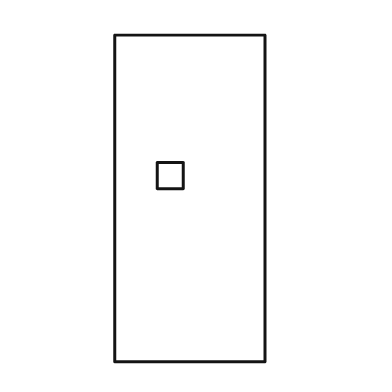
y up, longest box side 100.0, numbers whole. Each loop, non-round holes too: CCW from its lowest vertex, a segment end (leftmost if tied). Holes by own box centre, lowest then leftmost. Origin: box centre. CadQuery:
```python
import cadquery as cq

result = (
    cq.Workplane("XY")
    .moveTo(-23.0, -50.0)
    .lineTo(23.0, -50.0)
    .lineTo(23.0, 50.0)
    .lineTo(-23.0, 50.0)
    .close()
    .moveTo(-10.0, 3.0)
    .lineTo(-2.0, 3.0)
    .lineTo(-2.0, 11.0)
    .lineTo(-10.0, 11.0)
    .close()
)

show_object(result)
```